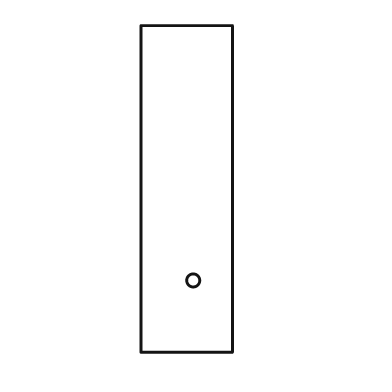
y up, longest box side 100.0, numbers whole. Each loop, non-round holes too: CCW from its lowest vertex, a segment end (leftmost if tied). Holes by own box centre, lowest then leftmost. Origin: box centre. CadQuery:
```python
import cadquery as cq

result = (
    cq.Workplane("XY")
    .moveTo(-14.0, -50.0)
    .lineTo(14.0, -50.0)
    .lineTo(14.0, 50.0)
    .lineTo(-14.0, 50.0)
    .close()
    .moveTo(2.0, -28.0)
    .circle(2.0)
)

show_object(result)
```